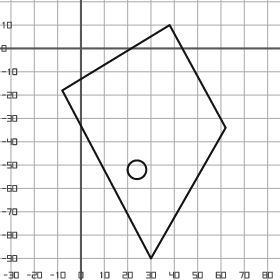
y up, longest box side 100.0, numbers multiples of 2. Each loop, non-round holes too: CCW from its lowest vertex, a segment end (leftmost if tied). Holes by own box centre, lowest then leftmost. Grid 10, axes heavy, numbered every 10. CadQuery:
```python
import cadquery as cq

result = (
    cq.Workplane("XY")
    .moveTo(30.0, -90.0)
    .lineTo(62.0, -34.0)
    .lineTo(38.0, 10.0)
    .lineTo(-8.0, -18.0)
    .close()
    .moveTo(24.0, -52.0)
    .circle(4.0)
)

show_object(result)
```